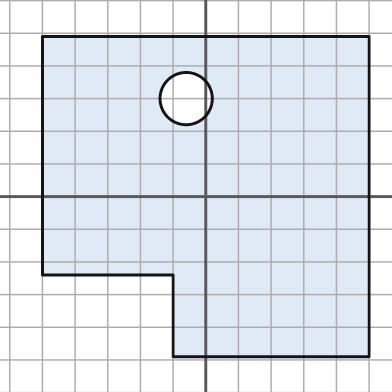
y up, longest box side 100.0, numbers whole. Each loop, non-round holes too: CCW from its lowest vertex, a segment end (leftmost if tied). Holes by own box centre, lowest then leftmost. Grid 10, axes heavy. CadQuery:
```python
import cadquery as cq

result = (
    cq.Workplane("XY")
    .moveTo(-10.0, -49.0)
    .lineTo(50.0, -49.0)
    .lineTo(50.0, 49.0)
    .lineTo(-50.0, 49.0)
    .lineTo(-50.0, -24.0)
    .lineTo(-10.0, -24.0)
    .close()
    .moveTo(-6.0, 30.0)
    .circle(8.0)
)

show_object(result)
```